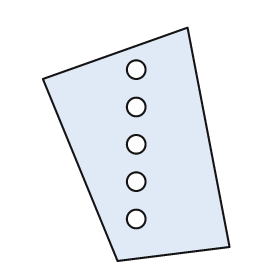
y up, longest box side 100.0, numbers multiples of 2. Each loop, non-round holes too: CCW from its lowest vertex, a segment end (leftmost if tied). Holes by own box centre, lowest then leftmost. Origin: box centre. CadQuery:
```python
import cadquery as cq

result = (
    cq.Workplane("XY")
    .moveTo(-8.0, -50.0)
    .lineTo(40.0, -44.0)
    .lineTo(22.0, 50.0)
    .lineTo(-40.0, 28.0)
    .close()
    .moveTo(0.0, -32.0)
    .circle(4.0)
    .moveTo(0.0, -16.0)
    .circle(4.0)
    .moveTo(0.0, 0.0)
    .circle(4.0)
    .moveTo(0.0, 16.0)
    .circle(4.0)
    .moveTo(0.0, 32.0)
    .circle(4.0)
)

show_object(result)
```